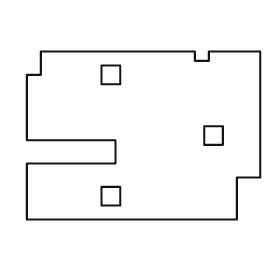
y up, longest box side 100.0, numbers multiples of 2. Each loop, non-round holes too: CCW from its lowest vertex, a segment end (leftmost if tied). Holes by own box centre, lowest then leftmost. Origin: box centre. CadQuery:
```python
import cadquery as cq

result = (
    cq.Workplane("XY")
    .moveTo(-50.0, -36.0)
    .lineTo(40.0, -36.0)
    .lineTo(40.0, -18.0)
    .lineTo(50.0, -18.0)
    .lineTo(50.0, 36.0)
    .lineTo(28.0, 36.0)
    .lineTo(28.0, 32.0)
    .lineTo(22.0, 32.0)
    .lineTo(22.0, 36.0)
    .lineTo(-44.0, 36.0)
    .lineTo(-44.0, 26.0)
    .lineTo(-50.0, 26.0)
    .lineTo(-50.0, -2.0)
    .lineTo(-12.0, -2.0)
    .lineTo(-12.0, -12.0)
    .lineTo(-50.0, -12.0)
    .close()
    .moveTo(-18.0, -30.0)
    .lineTo(-10.0, -30.0)
    .lineTo(-10.0, -22.0)
    .lineTo(-18.0, -22.0)
    .close()
    .moveTo(26.0, -4.0)
    .lineTo(34.0, -4.0)
    .lineTo(34.0, 4.0)
    .lineTo(26.0, 4.0)
    .close()
    .moveTo(-18.0, 22.0)
    .lineTo(-10.0, 22.0)
    .lineTo(-10.0, 30.0)
    .lineTo(-18.0, 30.0)
    .close()
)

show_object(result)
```